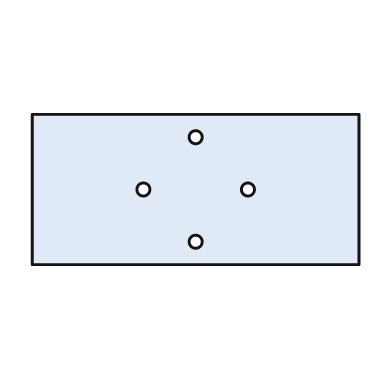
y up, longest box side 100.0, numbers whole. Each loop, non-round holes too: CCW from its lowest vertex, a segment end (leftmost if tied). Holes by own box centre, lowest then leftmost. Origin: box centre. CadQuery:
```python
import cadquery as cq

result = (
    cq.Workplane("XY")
    .moveTo(-50.0, -23.0)
    .lineTo(50.0, -23.0)
    .lineTo(50.0, 23.0)
    .lineTo(-50.0, 23.0)
    .close()
    .moveTo(0.0, -16.0)
    .circle(2.0)
    .moveTo(-16.0, 0.0)
    .circle(2.0)
    .moveTo(16.0, 0.0)
    .circle(2.0)
    .moveTo(0.0, 16.0)
    .circle(2.0)
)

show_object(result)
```